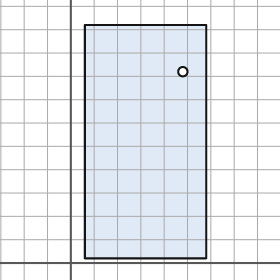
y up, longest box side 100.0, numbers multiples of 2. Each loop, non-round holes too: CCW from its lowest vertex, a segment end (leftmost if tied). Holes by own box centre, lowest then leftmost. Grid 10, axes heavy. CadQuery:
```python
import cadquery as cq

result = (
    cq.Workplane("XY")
    .moveTo(6.0, 2.0)
    .lineTo(58.0, 2.0)
    .lineTo(58.0, 102.0)
    .lineTo(6.0, 102.0)
    .close()
    .moveTo(48.0, 82.0)
    .circle(2.0)
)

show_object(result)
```